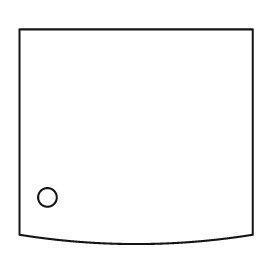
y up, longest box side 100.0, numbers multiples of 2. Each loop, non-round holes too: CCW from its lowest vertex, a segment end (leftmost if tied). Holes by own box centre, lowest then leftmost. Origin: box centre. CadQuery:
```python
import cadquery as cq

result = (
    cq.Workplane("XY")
    .moveTo(-50.0, -42.0)
    .threePointArc((0.0, -46.0), (50.0, -42.0))
    .lineTo(50.0, 46.0)
    .lineTo(-50.0, 46.0)
    .close()
    .moveTo(-38.0, -26.0)
    .circle(4.0)
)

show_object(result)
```